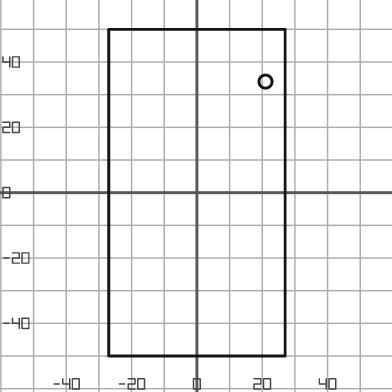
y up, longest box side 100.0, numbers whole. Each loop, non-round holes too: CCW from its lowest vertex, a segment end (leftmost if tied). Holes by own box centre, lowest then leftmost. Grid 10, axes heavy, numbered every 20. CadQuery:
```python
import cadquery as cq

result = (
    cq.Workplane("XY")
    .moveTo(-27.0, -50.0)
    .lineTo(27.0, -50.0)
    .lineTo(27.0, 50.0)
    .lineTo(-27.0, 50.0)
    .close()
    .moveTo(21.0, 34.0)
    .circle(2.0)
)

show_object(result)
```